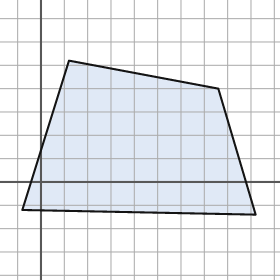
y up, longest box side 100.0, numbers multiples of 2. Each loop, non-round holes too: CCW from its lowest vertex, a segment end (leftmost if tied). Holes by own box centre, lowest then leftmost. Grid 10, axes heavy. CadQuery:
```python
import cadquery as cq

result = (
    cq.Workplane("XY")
    .moveTo(92.0, -14.0)
    .lineTo(76.0, 40.0)
    .lineTo(12.0, 52.0)
    .lineTo(-8.0, -12.0)
    .close()
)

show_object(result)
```